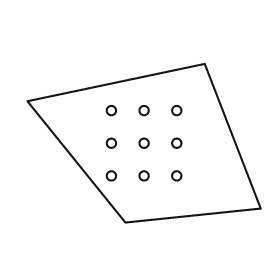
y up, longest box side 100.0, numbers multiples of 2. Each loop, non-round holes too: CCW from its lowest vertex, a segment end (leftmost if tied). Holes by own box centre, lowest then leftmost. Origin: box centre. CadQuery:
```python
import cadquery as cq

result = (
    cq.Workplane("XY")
    .moveTo(-8.0, -34.0)
    .lineTo(50.0, -28.0)
    .lineTo(26.0, 34.0)
    .lineTo(-50.0, 18.0)
    .close()
    .moveTo(-14.0, -14.0)
    .circle(2.0)
    .moveTo(0.0, -14.0)
    .circle(2.0)
    .moveTo(14.0, -14.0)
    .circle(2.0)
    .moveTo(-14.0, 0.0)
    .circle(2.0)
    .moveTo(0.0, 0.0)
    .circle(2.0)
    .moveTo(14.0, 0.0)
    .circle(2.0)
    .moveTo(-14.0, 14.0)
    .circle(2.0)
    .moveTo(0.0, 14.0)
    .circle(2.0)
    .moveTo(14.0, 14.0)
    .circle(2.0)
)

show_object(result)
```